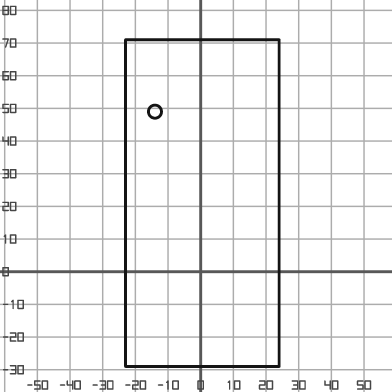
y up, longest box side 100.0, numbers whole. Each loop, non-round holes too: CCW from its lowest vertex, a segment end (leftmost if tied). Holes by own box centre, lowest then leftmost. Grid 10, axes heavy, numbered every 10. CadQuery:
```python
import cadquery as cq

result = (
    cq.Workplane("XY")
    .moveTo(-23.0, -29.0)
    .lineTo(24.0, -29.0)
    .lineTo(24.0, 71.0)
    .lineTo(-23.0, 71.0)
    .close()
    .moveTo(-14.0, 49.0)
    .circle(2.0)
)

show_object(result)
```